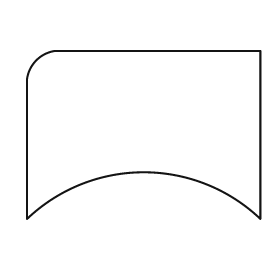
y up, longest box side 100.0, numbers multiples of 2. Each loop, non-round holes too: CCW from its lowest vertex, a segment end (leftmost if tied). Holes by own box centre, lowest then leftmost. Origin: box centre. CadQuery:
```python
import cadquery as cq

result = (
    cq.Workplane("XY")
    .moveTo(-50.0, -36.0)
    .threePointArc((0.0, -16.0), (50.0, -36.0))
    .lineTo(50.0, 36.0)
    .lineTo(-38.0, 36.0)
    .threePointArc((-46.0, 32.0), (-50.0, 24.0))
    .close()
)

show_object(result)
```